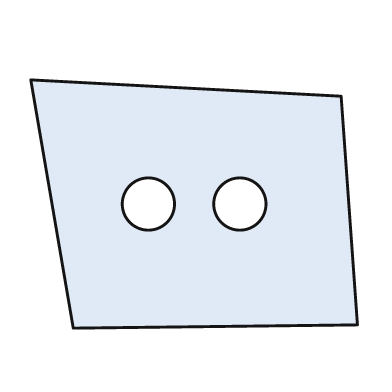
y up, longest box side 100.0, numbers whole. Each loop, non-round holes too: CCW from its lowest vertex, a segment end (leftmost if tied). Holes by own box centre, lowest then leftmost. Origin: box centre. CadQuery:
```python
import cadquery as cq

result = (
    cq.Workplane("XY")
    .moveTo(-37.0, -38.0)
    .lineTo(50.0, -37.0)
    .lineTo(45.0, 33.0)
    .lineTo(-50.0, 38.0)
    .close()
    .moveTo(-14.0, 0.0)
    .circle(8.0)
    .moveTo(14.0, 0.0)
    .circle(8.0)
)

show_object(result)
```